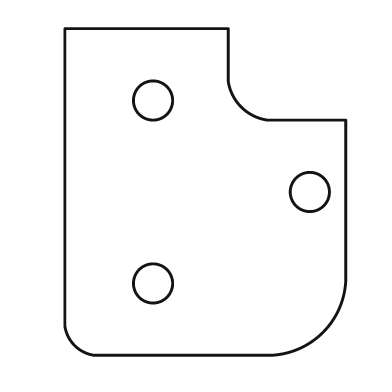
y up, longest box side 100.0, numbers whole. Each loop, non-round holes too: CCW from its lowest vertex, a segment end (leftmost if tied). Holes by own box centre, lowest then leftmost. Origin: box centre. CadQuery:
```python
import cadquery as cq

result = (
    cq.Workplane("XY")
    .moveTo(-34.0, -50.0)
    .lineTo(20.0, -50.0)
    .threePointArc((36.0, -43.0), (43.0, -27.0))
    .lineTo(43.0, 22.0)
    .lineTo(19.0, 22.0)
    .threePointArc((11.0, 26.0), (7.0, 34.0))
    .lineTo(7.0, 50.0)
    .lineTo(-43.0, 50.0)
    .lineTo(-43.0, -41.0)
    .threePointArc((-40.0, -47.0), (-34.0, -50.0))
    .close()
    .moveTo(-16.0, -28.0)
    .circle(6.0)
    .moveTo(32.0, 0.0)
    .circle(6.0)
    .moveTo(-16.0, 28.0)
    .circle(6.0)
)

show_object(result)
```